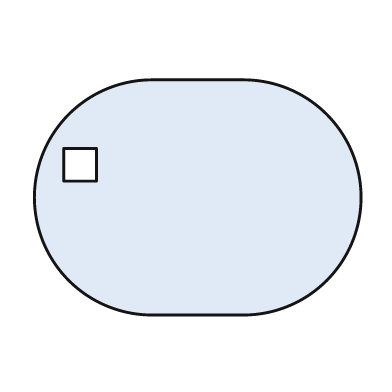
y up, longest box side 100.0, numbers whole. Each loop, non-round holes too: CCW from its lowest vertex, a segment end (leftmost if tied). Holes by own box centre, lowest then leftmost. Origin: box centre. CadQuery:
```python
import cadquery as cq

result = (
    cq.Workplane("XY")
    .moveTo(-14.0, -36.0)
    .lineTo(14.0, -36.0)
    .threePointArc((50.0, 0.0), (14.0, 36.0))
    .lineTo(-14.0, 36.0)
    .threePointArc((-50.0, 0.0), (-14.0, -36.0))
    .close()
    .moveTo(-41.0, 5.0)
    .lineTo(-31.0, 5.0)
    .lineTo(-31.0, 15.0)
    .lineTo(-41.0, 15.0)
    .close()
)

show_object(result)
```